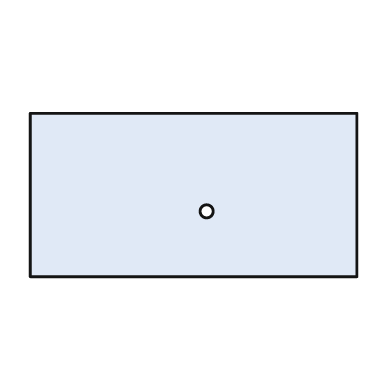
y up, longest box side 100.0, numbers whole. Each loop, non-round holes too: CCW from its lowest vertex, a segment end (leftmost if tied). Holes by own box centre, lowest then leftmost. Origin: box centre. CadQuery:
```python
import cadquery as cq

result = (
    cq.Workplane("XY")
    .moveTo(-50.0, -25.0)
    .lineTo(50.0, -25.0)
    .lineTo(50.0, 25.0)
    .lineTo(-50.0, 25.0)
    .close()
    .moveTo(4.0, -5.0)
    .circle(2.0)
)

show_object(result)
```